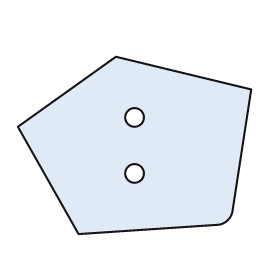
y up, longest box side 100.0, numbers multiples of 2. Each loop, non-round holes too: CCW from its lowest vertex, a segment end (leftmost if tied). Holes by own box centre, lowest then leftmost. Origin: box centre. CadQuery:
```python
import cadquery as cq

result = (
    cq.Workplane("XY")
    .moveTo(-24.0, -38.0)
    .lineTo(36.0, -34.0)
    .threePointArc((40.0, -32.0), (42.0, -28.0))
    .lineTo(50.0, 24.0)
    .lineTo(-8.0, 38.0)
    .lineTo(-50.0, 8.0)
    .close()
    .moveTo(0.0, -12.0)
    .circle(4.0)
    .moveTo(0.0, 12.0)
    .circle(4.0)
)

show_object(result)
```